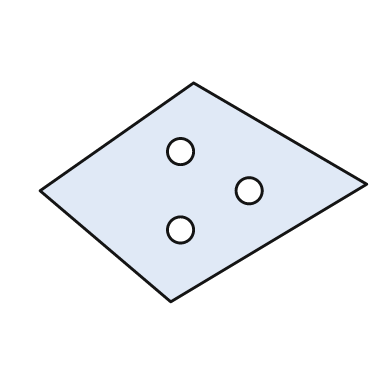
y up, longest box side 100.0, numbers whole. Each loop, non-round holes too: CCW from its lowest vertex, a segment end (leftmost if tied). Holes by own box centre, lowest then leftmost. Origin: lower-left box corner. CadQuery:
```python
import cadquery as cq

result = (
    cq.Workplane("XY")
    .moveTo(40.0, 0.0)
    .lineTo(100.0, 36.0)
    .lineTo(47.0, 67.0)
    .lineTo(0.0, 34.0)
    .close()
    .moveTo(43.0, 22.0)
    .circle(4.0)
    .moveTo(64.0, 34.0)
    .circle(4.0)
    .moveTo(43.0, 46.0)
    .circle(4.0)
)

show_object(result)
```